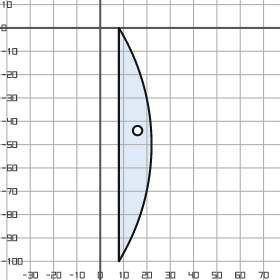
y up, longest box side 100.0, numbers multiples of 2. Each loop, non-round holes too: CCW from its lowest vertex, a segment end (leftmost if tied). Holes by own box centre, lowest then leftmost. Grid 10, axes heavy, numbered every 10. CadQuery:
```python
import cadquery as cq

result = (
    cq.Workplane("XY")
    .moveTo(8.0, -100.0)
    .threePointArc((22.0, -50.0), (8.0, 0.0))
    .close()
    .moveTo(16.0, -44.0)
    .circle(2.0)
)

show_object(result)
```